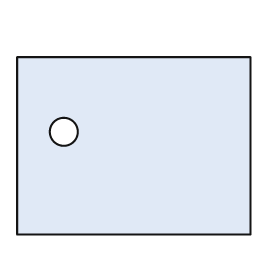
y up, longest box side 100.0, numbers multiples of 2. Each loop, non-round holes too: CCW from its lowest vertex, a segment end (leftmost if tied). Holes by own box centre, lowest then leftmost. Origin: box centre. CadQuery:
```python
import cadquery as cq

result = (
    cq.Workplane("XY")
    .moveTo(-50.0, -38.0)
    .lineTo(50.0, -38.0)
    .lineTo(50.0, 38.0)
    .lineTo(-50.0, 38.0)
    .close()
    .moveTo(-30.0, 6.0)
    .circle(6.0)
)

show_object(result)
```